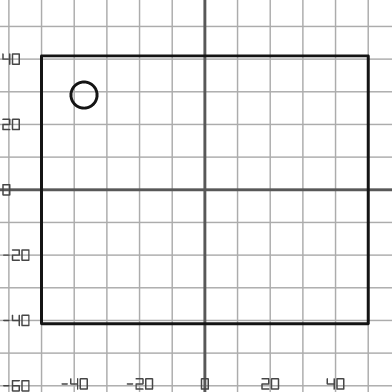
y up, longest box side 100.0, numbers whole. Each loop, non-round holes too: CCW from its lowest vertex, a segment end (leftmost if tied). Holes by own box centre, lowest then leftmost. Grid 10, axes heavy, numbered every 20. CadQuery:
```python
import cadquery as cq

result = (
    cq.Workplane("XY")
    .moveTo(-50.0, -41.0)
    .lineTo(50.0, -41.0)
    .lineTo(50.0, 41.0)
    .lineTo(-50.0, 41.0)
    .close()
    .moveTo(-37.0, 29.0)
    .circle(4.0)
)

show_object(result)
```